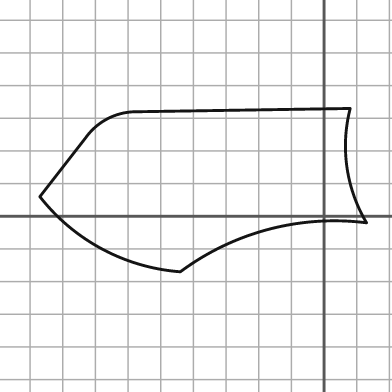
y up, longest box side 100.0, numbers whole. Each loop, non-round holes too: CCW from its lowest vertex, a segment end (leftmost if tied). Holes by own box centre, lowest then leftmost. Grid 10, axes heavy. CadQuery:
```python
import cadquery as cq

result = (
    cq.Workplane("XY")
    .moveTo(-44.0, -17.0)
    .threePointArc((-17.0, -4.0), (13.0, -2.0))
    .threePointArc((7.0, 15.0), (8.0, 33.0))
    .lineTo(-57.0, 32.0)
    .threePointArc((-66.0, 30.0), (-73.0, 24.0))
    .lineTo(-87.0, 6.0)
    .threePointArc((-68.0, -10.0), (-44.0, -17.0))
    .close()
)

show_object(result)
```